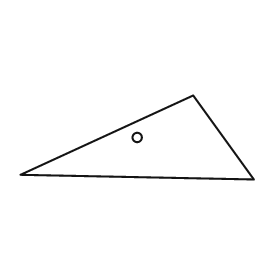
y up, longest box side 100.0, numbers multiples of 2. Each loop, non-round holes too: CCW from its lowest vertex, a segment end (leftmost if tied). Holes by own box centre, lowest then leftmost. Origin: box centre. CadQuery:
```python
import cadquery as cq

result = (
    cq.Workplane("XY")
    .moveTo(50.0, -18.0)
    .lineTo(24.0, 18.0)
    .lineTo(-50.0, -16.0)
    .close()
    .moveTo(0.0, 0.0)
    .circle(2.0)
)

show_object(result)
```